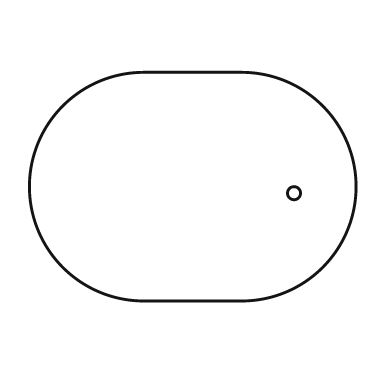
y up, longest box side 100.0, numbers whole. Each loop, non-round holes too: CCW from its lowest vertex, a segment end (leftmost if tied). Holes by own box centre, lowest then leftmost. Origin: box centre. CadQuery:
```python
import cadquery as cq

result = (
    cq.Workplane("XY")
    .moveTo(-15.0, -35.0)
    .lineTo(15.0, -35.0)
    .threePointArc((50.0, 0.0), (15.0, 35.0))
    .lineTo(-15.0, 35.0)
    .threePointArc((-50.0, 0.0), (-15.0, -35.0))
    .close()
    .moveTo(31.0, -2.0)
    .circle(2.0)
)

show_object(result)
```